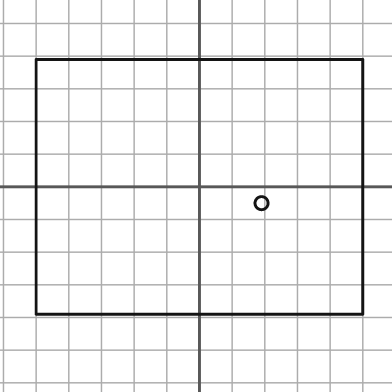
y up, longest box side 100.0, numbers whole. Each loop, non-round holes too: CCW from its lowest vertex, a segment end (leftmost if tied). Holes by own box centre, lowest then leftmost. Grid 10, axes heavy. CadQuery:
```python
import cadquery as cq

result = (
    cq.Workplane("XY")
    .moveTo(-50.0, -39.0)
    .lineTo(50.0, -39.0)
    .lineTo(50.0, 39.0)
    .lineTo(-50.0, 39.0)
    .close()
    .moveTo(19.0, -5.0)
    .circle(2.0)
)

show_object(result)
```